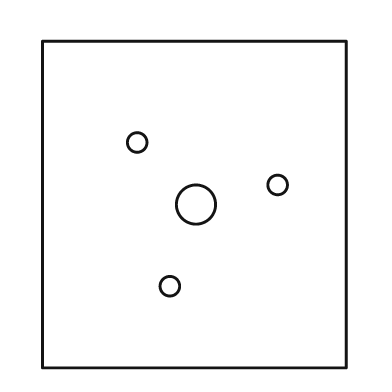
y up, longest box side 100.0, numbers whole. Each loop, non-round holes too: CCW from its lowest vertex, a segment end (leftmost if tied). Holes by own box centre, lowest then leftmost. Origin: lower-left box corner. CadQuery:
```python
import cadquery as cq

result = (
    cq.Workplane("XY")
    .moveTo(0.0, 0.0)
    .lineTo(93.0, 0.0)
    .lineTo(93.0, 100.0)
    .lineTo(0.0, 100.0)
    .close()
    .moveTo(39.0, 25.0)
    .circle(3.0)
    .moveTo(47.0, 50.0)
    .circle(6.0)
    .moveTo(72.0, 56.0)
    .circle(3.0)
    .moveTo(29.0, 69.0)
    .circle(3.0)
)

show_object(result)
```